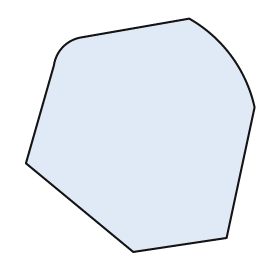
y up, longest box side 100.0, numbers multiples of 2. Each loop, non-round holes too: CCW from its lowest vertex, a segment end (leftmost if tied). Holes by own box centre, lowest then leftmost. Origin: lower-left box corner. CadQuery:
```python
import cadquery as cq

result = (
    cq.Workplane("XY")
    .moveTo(46.0, 0.0)
    .lineTo(86.0, 6.0)
    .lineTo(98.0, 62.0)
    .threePointArc((88.0, 84.0), (70.0, 100.0))
    .lineTo(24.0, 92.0)
    .threePointArc((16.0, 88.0), (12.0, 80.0))
    .lineTo(0.0, 38.0)
    .close()
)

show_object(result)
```